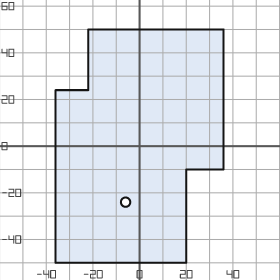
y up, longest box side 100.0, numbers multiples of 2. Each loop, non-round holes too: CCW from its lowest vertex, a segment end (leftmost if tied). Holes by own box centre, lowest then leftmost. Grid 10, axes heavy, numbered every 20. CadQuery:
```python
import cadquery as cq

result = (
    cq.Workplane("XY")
    .moveTo(-36.0, -50.0)
    .lineTo(20.0, -50.0)
    .lineTo(20.0, -10.0)
    .lineTo(36.0, -10.0)
    .lineTo(36.0, 50.0)
    .lineTo(-22.0, 50.0)
    .lineTo(-22.0, 24.0)
    .lineTo(-36.0, 24.0)
    .close()
    .moveTo(-6.0, -24.0)
    .circle(2.0)
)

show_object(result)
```